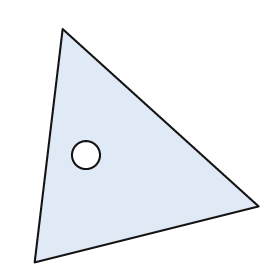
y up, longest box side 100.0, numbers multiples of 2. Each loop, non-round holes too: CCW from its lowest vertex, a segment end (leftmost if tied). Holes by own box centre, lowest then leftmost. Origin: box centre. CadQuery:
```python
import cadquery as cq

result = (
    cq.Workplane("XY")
    .moveTo(-48.0, -50.0)
    .lineTo(48.0, -26.0)
    .lineTo(-36.0, 50.0)
    .close()
    .moveTo(-26.0, -4.0)
    .circle(6.0)
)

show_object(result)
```